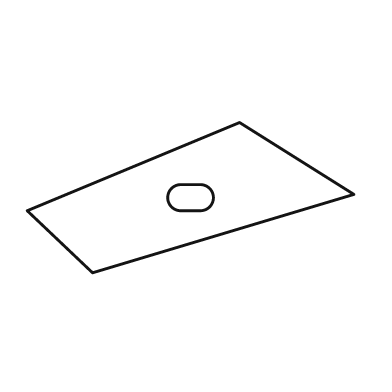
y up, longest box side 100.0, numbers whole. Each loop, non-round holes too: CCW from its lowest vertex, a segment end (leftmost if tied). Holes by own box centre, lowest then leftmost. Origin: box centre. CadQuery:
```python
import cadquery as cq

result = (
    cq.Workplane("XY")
    .moveTo(-30.0, -23.0)
    .lineTo(50.0, 1.0)
    .lineTo(15.0, 23.0)
    .lineTo(-50.0, -4.0)
    .close()
    .moveTo(-3.0, -4.0)
    .lineTo(3.0, -4.0)
    .threePointArc((7.0, 0.0), (3.0, 4.0))
    .lineTo(-3.0, 4.0)
    .threePointArc((-7.0, 0.0), (-3.0, -4.0))
    .close()
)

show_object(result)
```